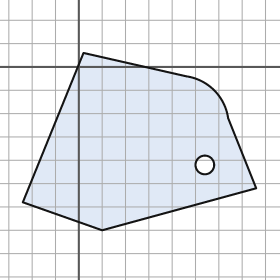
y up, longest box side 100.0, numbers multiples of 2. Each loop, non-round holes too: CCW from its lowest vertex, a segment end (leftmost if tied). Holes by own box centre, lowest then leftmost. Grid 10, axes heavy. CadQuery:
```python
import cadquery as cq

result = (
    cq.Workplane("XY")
    .moveTo(10.0, -70.0)
    .lineTo(76.0, -52.0)
    .lineTo(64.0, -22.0)
    .threePointArc((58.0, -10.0), (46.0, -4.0))
    .lineTo(2.0, 6.0)
    .lineTo(-24.0, -58.0)
    .close()
    .moveTo(54.0, -42.0)
    .circle(4.0)
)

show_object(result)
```